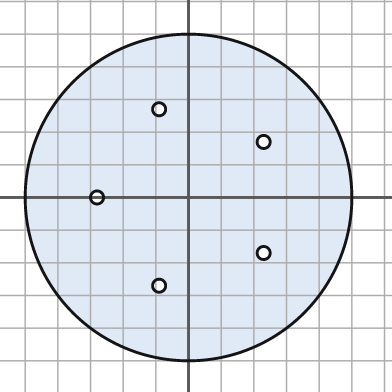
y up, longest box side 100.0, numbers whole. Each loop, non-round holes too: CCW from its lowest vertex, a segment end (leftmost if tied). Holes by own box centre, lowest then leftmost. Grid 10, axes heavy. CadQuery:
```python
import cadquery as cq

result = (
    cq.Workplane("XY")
    .moveTo(0.0, 0.0)
    .circle(50.0)
    .moveTo(-9.0, -27.0)
    .circle(2.0)
    .moveTo(23.0, -17.0)
    .circle(2.0)
    .moveTo(-28.0, 0.0)
    .circle(2.0)
    .moveTo(23.0, 17.0)
    .circle(2.0)
    .moveTo(-9.0, 27.0)
    .circle(2.0)
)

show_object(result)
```